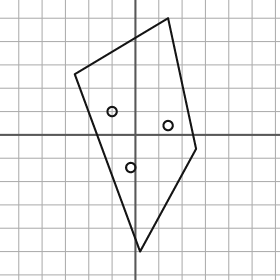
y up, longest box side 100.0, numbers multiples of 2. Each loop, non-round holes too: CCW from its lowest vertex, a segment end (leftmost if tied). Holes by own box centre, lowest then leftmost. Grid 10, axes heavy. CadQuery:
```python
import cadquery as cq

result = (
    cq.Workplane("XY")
    .moveTo(2.0, -50.0)
    .lineTo(26.0, -6.0)
    .lineTo(14.0, 50.0)
    .lineTo(-26.0, 26.0)
    .close()
    .moveTo(-2.0, -14.0)
    .circle(2.0)
    .moveTo(14.0, 4.0)
    .circle(2.0)
    .moveTo(-10.0, 10.0)
    .circle(2.0)
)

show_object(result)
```